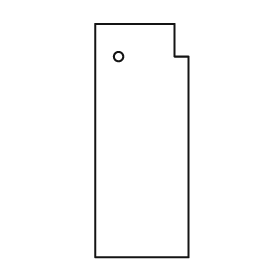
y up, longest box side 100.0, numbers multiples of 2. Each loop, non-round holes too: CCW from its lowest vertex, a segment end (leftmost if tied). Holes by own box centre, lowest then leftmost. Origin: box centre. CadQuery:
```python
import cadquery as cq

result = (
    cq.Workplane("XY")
    .moveTo(-20.0, -50.0)
    .lineTo(20.0, -50.0)
    .lineTo(20.0, 36.0)
    .lineTo(14.0, 36.0)
    .lineTo(14.0, 50.0)
    .lineTo(-20.0, 50.0)
    .close()
    .moveTo(-10.0, 36.0)
    .circle(2.0)
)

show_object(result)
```